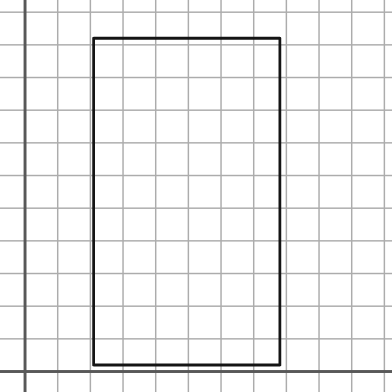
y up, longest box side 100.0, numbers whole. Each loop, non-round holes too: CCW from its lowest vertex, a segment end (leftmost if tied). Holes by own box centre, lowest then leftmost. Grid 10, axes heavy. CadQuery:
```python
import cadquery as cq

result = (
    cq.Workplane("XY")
    .moveTo(21.0, 2.0)
    .lineTo(78.0, 2.0)
    .lineTo(78.0, 102.0)
    .lineTo(21.0, 102.0)
    .close()
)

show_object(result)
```